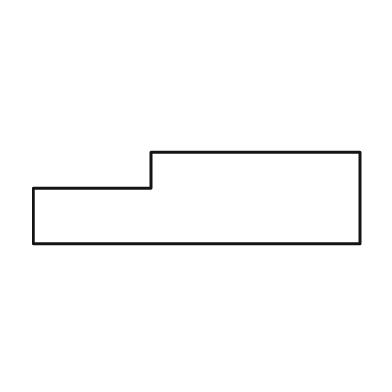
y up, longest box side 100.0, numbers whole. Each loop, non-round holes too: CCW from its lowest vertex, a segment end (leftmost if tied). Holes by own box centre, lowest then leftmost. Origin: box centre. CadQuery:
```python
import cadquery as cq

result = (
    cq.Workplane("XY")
    .moveTo(-50.0, -14.0)
    .lineTo(50.0, -14.0)
    .lineTo(50.0, 14.0)
    .lineTo(-14.0, 14.0)
    .lineTo(-14.0, 3.0)
    .lineTo(-50.0, 3.0)
    .close()
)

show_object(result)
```